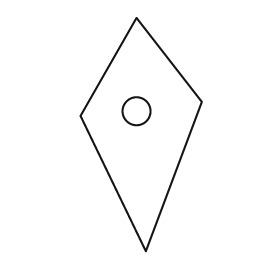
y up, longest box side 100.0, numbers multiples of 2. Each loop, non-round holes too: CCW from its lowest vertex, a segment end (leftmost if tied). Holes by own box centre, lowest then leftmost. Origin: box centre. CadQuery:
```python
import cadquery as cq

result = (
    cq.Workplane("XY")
    .moveTo(2.0, -50.0)
    .lineTo(26.0, 14.0)
    .lineTo(-2.0, 50.0)
    .lineTo(-26.0, 8.0)
    .close()
    .moveTo(-2.0, 10.0)
    .circle(6.0)
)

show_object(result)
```